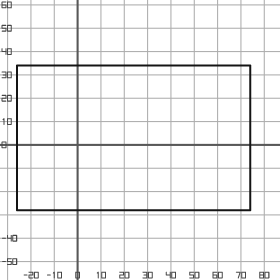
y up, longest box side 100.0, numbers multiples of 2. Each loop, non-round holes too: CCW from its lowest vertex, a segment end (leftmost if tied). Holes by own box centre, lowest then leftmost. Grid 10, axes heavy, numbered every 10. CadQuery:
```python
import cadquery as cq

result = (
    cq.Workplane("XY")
    .moveTo(-26.0, -28.0)
    .lineTo(74.0, -28.0)
    .lineTo(74.0, 34.0)
    .lineTo(-26.0, 34.0)
    .close()
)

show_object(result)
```